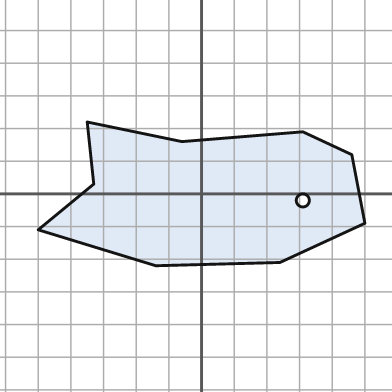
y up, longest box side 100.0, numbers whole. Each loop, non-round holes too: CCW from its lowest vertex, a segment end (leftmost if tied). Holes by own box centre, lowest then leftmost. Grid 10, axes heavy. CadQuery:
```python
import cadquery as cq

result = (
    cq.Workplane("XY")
    .moveTo(-14.0, -22.0)
    .lineTo(24.0, -21.0)
    .lineTo(50.0, -9.0)
    .lineTo(46.0, 12.0)
    .lineTo(31.0, 19.0)
    .lineTo(-6.0, 16.0)
    .lineTo(-35.0, 22.0)
    .lineTo(-33.0, 3.0)
    .lineTo(-50.0, -11.0)
    .close()
    .moveTo(31.0, -2.0)
    .circle(2.0)
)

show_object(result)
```